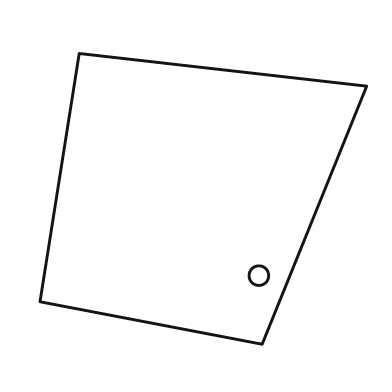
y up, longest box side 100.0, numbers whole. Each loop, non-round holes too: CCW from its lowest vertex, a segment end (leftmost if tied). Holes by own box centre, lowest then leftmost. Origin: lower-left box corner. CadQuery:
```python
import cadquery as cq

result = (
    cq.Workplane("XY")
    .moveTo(68.0, 0.0)
    .lineTo(100.0, 79.0)
    .lineTo(12.0, 89.0)
    .lineTo(0.0, 13.0)
    .close()
    .moveTo(67.0, 21.0)
    .circle(3.0)
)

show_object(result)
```